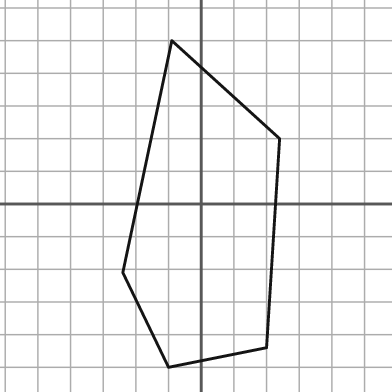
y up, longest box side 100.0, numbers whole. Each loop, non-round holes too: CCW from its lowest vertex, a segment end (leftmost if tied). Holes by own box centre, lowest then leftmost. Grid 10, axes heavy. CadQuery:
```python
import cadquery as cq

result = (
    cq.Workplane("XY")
    .moveTo(-10.0, -50.0)
    .lineTo(20.0, -44.0)
    .lineTo(24.0, 20.0)
    .lineTo(-9.0, 50.0)
    .lineTo(-24.0, -21.0)
    .close()
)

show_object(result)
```